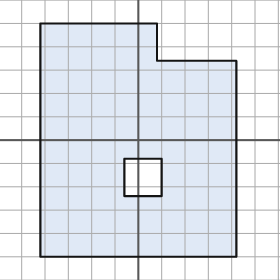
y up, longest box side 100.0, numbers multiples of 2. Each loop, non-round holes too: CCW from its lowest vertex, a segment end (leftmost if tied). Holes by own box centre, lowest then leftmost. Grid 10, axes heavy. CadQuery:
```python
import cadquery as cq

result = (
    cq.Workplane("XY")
    .moveTo(-42.0, -50.0)
    .lineTo(42.0, -50.0)
    .lineTo(42.0, 34.0)
    .lineTo(8.0, 34.0)
    .lineTo(8.0, 50.0)
    .lineTo(-42.0, 50.0)
    .close()
    .moveTo(-6.0, -24.0)
    .lineTo(10.0, -24.0)
    .lineTo(10.0, -8.0)
    .lineTo(-6.0, -8.0)
    .close()
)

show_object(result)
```